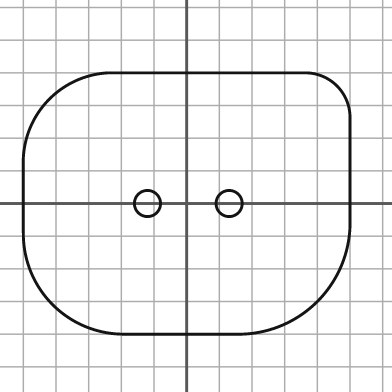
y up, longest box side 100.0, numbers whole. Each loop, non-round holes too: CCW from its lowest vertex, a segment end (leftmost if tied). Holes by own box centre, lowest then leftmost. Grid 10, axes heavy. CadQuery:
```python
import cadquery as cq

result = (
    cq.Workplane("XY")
    .moveTo(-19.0, -40.0)
    .lineTo(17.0, -40.0)
    .threePointArc((40.0, -30.0), (50.0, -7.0))
    .lineTo(50.0, 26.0)
    .threePointArc((46.0, 36.0), (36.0, 40.0))
    .lineTo(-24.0, 40.0)
    .threePointArc((-42.0, 32.0), (-50.0, 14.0))
    .lineTo(-50.0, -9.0)
    .threePointArc((-41.0, -31.0), (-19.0, -40.0))
    .close()
    .moveTo(-12.0, 0.0)
    .circle(4.0)
    .moveTo(13.0, 0.0)
    .circle(4.0)
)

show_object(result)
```